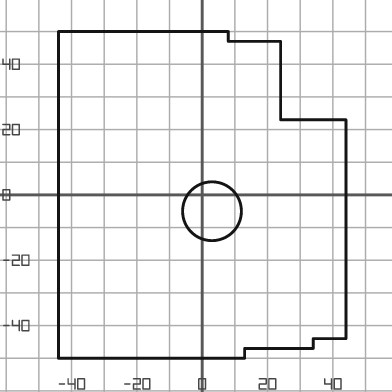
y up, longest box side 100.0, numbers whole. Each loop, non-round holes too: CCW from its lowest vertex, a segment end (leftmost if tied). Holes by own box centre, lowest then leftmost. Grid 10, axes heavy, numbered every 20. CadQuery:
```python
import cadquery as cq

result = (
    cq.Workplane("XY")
    .moveTo(-44.0, -50.0)
    .lineTo(13.0, -50.0)
    .lineTo(13.0, -47.0)
    .lineTo(34.0, -47.0)
    .lineTo(34.0, -44.0)
    .lineTo(44.0, -44.0)
    .lineTo(44.0, 23.0)
    .lineTo(24.0, 23.0)
    .lineTo(24.0, 47.0)
    .lineTo(8.0, 47.0)
    .lineTo(8.0, 50.0)
    .lineTo(-44.0, 50.0)
    .close()
    .moveTo(3.0, -5.0)
    .circle(9.0)
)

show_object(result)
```